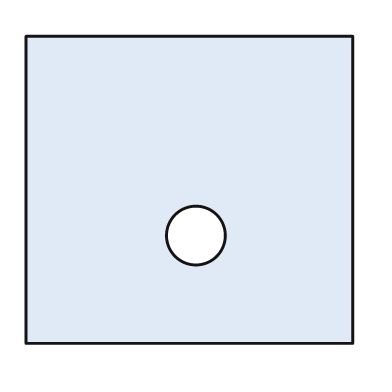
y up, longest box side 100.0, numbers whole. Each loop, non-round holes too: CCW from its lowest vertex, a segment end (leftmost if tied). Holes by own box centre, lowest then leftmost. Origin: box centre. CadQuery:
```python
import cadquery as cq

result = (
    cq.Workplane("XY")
    .moveTo(-50.0, -47.0)
    .lineTo(50.0, -47.0)
    .lineTo(50.0, 47.0)
    .lineTo(-50.0, 47.0)
    .close()
    .moveTo(2.0, -14.0)
    .circle(9.0)
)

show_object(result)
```